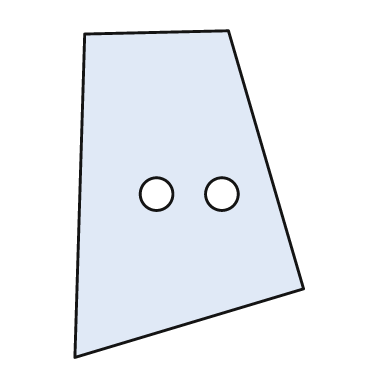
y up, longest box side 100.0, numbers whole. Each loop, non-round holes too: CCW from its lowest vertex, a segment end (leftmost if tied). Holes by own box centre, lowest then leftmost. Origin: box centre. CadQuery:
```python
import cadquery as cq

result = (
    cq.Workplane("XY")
    .moveTo(-35.0, -50.0)
    .lineTo(35.0, -29.0)
    .lineTo(12.0, 50.0)
    .lineTo(-32.0, 49.0)
    .close()
    .moveTo(-10.0, 0.0)
    .circle(5.0)
    .moveTo(10.0, 0.0)
    .circle(5.0)
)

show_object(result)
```